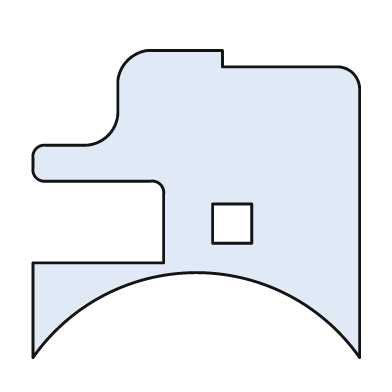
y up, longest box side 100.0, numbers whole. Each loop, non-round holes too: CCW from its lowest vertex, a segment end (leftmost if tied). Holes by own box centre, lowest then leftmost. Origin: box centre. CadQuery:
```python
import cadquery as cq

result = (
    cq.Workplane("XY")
    .moveTo(-50.0, -47.0)
    .threePointArc((0.0, -21.0), (50.0, -47.0))
    .lineTo(50.0, 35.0)
    .threePointArc((48.0, 40.0), (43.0, 42.0))
    .lineTo(8.0, 42.0)
    .lineTo(8.0, 47.0)
    .lineTo(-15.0, 47.0)
    .threePointArc((-21.0, 44.0), (-24.0, 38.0))
    .lineTo(-24.0, 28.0)
    .threePointArc((-27.0, 21.0), (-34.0, 18.0))
    .lineTo(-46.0, 18.0)
    .threePointArc((-49.0, 17.0), (-50.0, 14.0))
    .lineTo(-50.0, 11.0)
    .threePointArc((-49.0, 8.0), (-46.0, 7.0))
    .lineTo(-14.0, 7.0)
    .threePointArc((-11.0, 6.0), (-10.0, 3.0))
    .lineTo(-10.0, -18.0)
    .lineTo(-50.0, -18.0)
    .close()
    .moveTo(5.0, -12.0)
    .lineTo(17.0, -12.0)
    .lineTo(17.0, 0.0)
    .lineTo(5.0, 0.0)
    .close()
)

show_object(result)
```